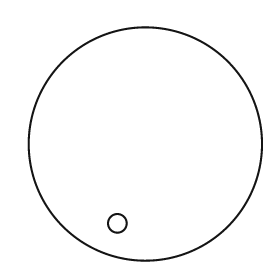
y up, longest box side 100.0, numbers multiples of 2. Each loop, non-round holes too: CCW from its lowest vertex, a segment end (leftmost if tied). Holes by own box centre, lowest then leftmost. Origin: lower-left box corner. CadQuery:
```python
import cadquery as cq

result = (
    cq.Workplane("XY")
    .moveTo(50.0, 50.0)
    .circle(50.0)
    .moveTo(38.0, 16.0)
    .circle(4.0)
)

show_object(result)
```